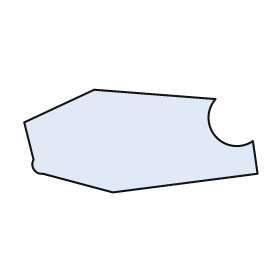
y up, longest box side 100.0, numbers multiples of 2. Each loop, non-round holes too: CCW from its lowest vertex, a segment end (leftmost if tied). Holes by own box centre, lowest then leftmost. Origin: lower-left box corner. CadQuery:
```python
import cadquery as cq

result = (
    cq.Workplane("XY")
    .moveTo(38.0, 0.0)
    .lineTo(100.0, 8.0)
    .lineTo(98.0, 22.0)
    .threePointArc((82.0, 24.0), (82.0, 40.0))
    .lineTo(30.0, 44.0)
    .lineTo(0.0, 30.0)
    .lineTo(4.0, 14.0)
    .threePointArc((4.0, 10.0), (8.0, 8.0))
    .close()
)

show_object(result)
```